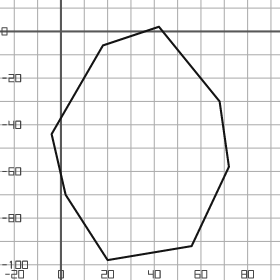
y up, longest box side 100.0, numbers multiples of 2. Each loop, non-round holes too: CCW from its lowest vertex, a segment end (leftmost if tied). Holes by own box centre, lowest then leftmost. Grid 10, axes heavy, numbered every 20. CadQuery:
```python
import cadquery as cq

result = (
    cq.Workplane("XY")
    .moveTo(20.0, -98.0)
    .lineTo(56.0, -92.0)
    .lineTo(72.0, -58.0)
    .lineTo(68.0, -30.0)
    .lineTo(42.0, 2.0)
    .lineTo(18.0, -6.0)
    .lineTo(-4.0, -44.0)
    .lineTo(2.0, -70.0)
    .close()
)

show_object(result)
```